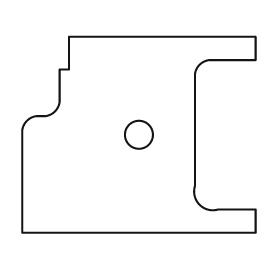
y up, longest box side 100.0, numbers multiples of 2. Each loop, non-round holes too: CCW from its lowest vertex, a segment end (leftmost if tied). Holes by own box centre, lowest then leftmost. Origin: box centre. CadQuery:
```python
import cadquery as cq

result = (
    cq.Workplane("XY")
    .moveTo(-50.0, -42.0)
    .lineTo(50.0, -42.0)
    .lineTo(50.0, -32.0)
    .lineTo(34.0, -32.0)
    .threePointArc((26.0, -30.0), (24.0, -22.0))
    .lineTo(24.0, 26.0)
    .threePointArc((26.0, 30.0), (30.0, 32.0))
    .lineTo(50.0, 32.0)
    .lineTo(50.0, 42.0)
    .lineTo(-30.0, 42.0)
    .lineTo(-30.0, 28.0)
    .lineTo(-34.0, 28.0)
    .lineTo(-34.0, 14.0)
    .threePointArc((-36.0, 10.0), (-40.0, 8.0))
    .lineTo(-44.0, 8.0)
    .threePointArc((-48.0, 6.0), (-50.0, 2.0))
    .close()
    .moveTo(0.0, 0.0)
    .circle(6.0)
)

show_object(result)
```